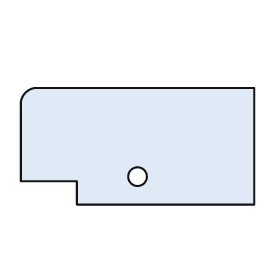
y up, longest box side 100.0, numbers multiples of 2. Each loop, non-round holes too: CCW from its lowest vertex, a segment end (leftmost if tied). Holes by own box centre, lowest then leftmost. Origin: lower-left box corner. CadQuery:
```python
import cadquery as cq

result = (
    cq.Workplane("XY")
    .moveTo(24.0, 0.0)
    .lineTo(100.0, 0.0)
    .lineTo(100.0, 50.0)
    .lineTo(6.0, 50.0)
    .threePointArc((2.0, 48.0), (0.0, 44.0))
    .lineTo(0.0, 10.0)
    .lineTo(24.0, 10.0)
    .close()
    .moveTo(50.0, 12.0)
    .circle(4.0)
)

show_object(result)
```